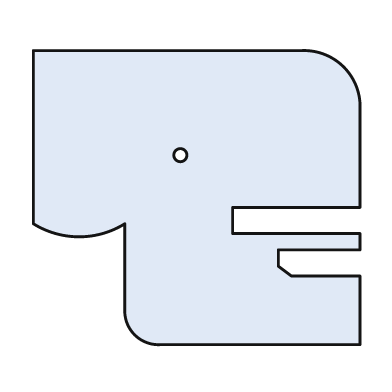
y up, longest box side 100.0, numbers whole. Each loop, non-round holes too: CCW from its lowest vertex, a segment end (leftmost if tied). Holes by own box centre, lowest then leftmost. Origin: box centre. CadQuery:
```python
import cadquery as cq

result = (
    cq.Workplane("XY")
    .moveTo(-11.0, -45.0)
    .lineTo(50.0, -45.0)
    .lineTo(50.0, -24.0)
    .lineTo(29.0, -24.0)
    .lineTo(25.0, -21.0)
    .lineTo(25.0, -16.0)
    .lineTo(50.0, -16.0)
    .lineTo(50.0, -11.0)
    .lineTo(11.0, -11.0)
    .lineTo(11.0, -3.0)
    .lineTo(50.0, -3.0)
    .lineTo(50.0, 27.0)
    .threePointArc((45.0, 40.0), (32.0, 45.0))
    .lineTo(-50.0, 45.0)
    .lineTo(-50.0, -8.0)
    .threePointArc((-36.0, -12.0), (-22.0, -8.0))
    .lineTo(-22.0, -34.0)
    .threePointArc((-19.0, -42.0), (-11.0, -45.0))
    .close()
    .moveTo(-5.0, 13.0)
    .circle(2.0)
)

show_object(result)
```